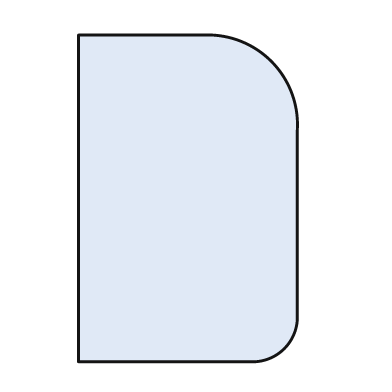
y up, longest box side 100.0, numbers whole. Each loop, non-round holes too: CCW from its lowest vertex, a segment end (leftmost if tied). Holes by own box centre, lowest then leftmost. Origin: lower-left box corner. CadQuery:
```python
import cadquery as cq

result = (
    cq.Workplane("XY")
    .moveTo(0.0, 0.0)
    .lineTo(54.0, 0.0)
    .threePointArc((63.0, 4.0), (67.0, 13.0))
    .lineTo(67.0, 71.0)
    .threePointArc((59.0, 92.0), (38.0, 100.0))
    .lineTo(0.0, 100.0)
    .close()
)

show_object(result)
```